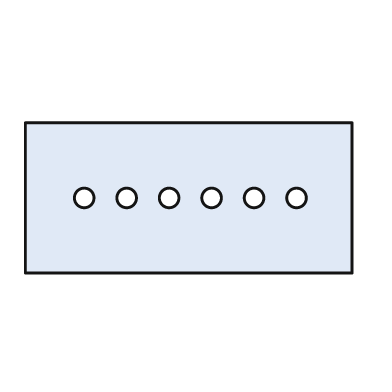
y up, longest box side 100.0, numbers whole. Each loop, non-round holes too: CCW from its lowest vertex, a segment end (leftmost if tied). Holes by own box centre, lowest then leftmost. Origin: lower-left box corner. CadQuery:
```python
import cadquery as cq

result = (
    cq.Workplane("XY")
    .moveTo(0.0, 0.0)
    .lineTo(100.0, 0.0)
    .lineTo(100.0, 46.0)
    .lineTo(0.0, 46.0)
    .close()
    .moveTo(18.0, 23.0)
    .circle(3.0)
    .moveTo(31.0, 23.0)
    .circle(3.0)
    .moveTo(44.0, 23.0)
    .circle(3.0)
    .moveTo(57.0, 23.0)
    .circle(3.0)
    .moveTo(70.0, 23.0)
    .circle(3.0)
    .moveTo(83.0, 23.0)
    .circle(3.0)
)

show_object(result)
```